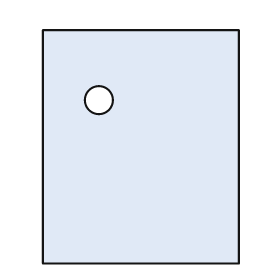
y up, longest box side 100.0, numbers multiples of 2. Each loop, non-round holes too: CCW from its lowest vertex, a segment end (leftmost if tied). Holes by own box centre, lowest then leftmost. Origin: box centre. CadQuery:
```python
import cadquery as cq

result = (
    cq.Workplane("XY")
    .moveTo(-42.0, -50.0)
    .lineTo(42.0, -50.0)
    .lineTo(42.0, 50.0)
    .lineTo(-42.0, 50.0)
    .close()
    .moveTo(-18.0, 20.0)
    .circle(6.0)
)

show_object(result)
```